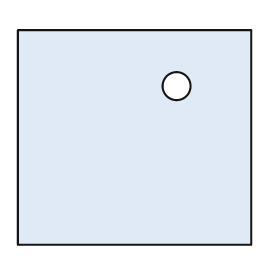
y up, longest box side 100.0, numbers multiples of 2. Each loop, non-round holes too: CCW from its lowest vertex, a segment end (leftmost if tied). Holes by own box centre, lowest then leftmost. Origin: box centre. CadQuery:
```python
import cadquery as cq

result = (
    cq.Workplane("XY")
    .moveTo(-50.0, -46.0)
    .lineTo(50.0, -46.0)
    .lineTo(50.0, 46.0)
    .lineTo(-50.0, 46.0)
    .close()
    .moveTo(18.0, 22.0)
    .circle(6.0)
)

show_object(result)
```